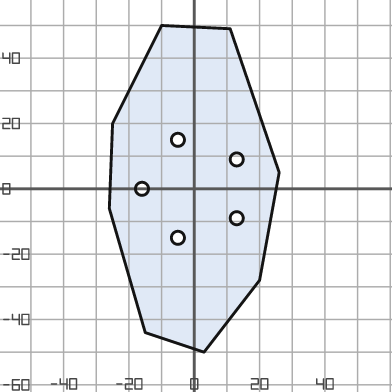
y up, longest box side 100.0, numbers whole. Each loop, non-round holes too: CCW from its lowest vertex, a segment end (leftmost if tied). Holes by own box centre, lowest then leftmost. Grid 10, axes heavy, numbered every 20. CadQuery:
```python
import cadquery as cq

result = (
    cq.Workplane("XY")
    .moveTo(3.0, -50.0)
    .lineTo(20.0, -28.0)
    .lineTo(26.0, 5.0)
    .lineTo(11.0, 49.0)
    .lineTo(-10.0, 50.0)
    .lineTo(-25.0, 20.0)
    .lineTo(-26.0, -6.0)
    .lineTo(-15.0, -44.0)
    .close()
    .moveTo(-5.0, -15.0)
    .circle(2.0)
    .moveTo(13.0, -9.0)
    .circle(2.0)
    .moveTo(-16.0, 0.0)
    .circle(2.0)
    .moveTo(13.0, 9.0)
    .circle(2.0)
    .moveTo(-5.0, 15.0)
    .circle(2.0)
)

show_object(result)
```